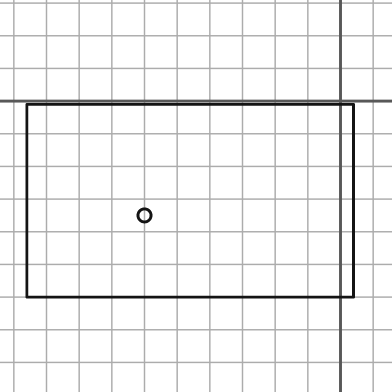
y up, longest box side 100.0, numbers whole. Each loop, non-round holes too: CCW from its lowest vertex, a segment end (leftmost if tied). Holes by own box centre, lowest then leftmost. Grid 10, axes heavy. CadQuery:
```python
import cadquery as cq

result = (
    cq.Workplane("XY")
    .moveTo(-96.0, -60.0)
    .lineTo(4.0, -60.0)
    .lineTo(4.0, -1.0)
    .lineTo(-96.0, -1.0)
    .close()
    .moveTo(-60.0, -35.0)
    .circle(2.0)
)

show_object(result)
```